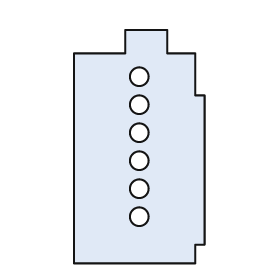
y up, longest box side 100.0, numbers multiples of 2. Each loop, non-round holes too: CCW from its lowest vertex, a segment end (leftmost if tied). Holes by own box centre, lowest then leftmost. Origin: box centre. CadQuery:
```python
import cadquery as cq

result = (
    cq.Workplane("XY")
    .moveTo(-28.0, -50.0)
    .lineTo(24.0, -50.0)
    .lineTo(24.0, -42.0)
    .lineTo(28.0, -42.0)
    .lineTo(28.0, 22.0)
    .lineTo(24.0, 22.0)
    .lineTo(24.0, 40.0)
    .lineTo(12.0, 40.0)
    .lineTo(12.0, 50.0)
    .lineTo(-6.0, 50.0)
    .lineTo(-6.0, 40.0)
    .lineTo(-28.0, 40.0)
    .close()
    .moveTo(0.0, -30.0)
    .circle(4.0)
    .moveTo(0.0, -18.0)
    .circle(4.0)
    .moveTo(0.0, -6.0)
    .circle(4.0)
    .moveTo(0.0, 6.0)
    .circle(4.0)
    .moveTo(0.0, 18.0)
    .circle(4.0)
    .moveTo(0.0, 30.0)
    .circle(4.0)
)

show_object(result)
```